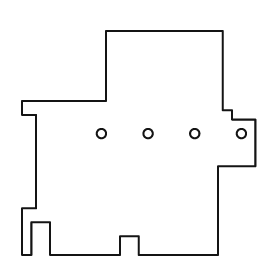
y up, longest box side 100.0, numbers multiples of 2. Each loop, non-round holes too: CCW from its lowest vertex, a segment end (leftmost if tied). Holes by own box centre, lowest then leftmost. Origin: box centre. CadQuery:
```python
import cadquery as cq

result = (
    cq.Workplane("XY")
    .moveTo(-50.0, -48.0)
    .lineTo(-46.0, -48.0)
    .lineTo(-46.0, -34.0)
    .lineTo(-38.0, -34.0)
    .lineTo(-38.0, -48.0)
    .lineTo(-8.0, -48.0)
    .lineTo(-8.0, -40.0)
    .lineTo(0.0, -40.0)
    .lineTo(0.0, -48.0)
    .lineTo(34.0, -48.0)
    .lineTo(34.0, -10.0)
    .lineTo(50.0, -10.0)
    .lineTo(50.0, 10.0)
    .lineTo(40.0, 10.0)
    .lineTo(40.0, 14.0)
    .lineTo(36.0, 14.0)
    .lineTo(36.0, 48.0)
    .lineTo(-14.0, 48.0)
    .lineTo(-14.0, 18.0)
    .lineTo(-50.0, 18.0)
    .lineTo(-50.0, 12.0)
    .lineTo(-44.0, 12.0)
    .lineTo(-44.0, -28.0)
    .lineTo(-50.0, -28.0)
    .close()
    .moveTo(-16.0, 4.0)
    .circle(2.0)
    .moveTo(4.0, 4.0)
    .circle(2.0)
    .moveTo(24.0, 4.0)
    .circle(2.0)
    .moveTo(44.0, 4.0)
    .circle(2.0)
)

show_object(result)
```